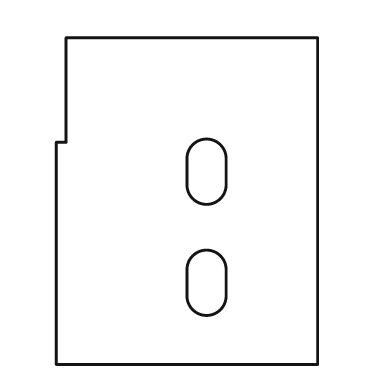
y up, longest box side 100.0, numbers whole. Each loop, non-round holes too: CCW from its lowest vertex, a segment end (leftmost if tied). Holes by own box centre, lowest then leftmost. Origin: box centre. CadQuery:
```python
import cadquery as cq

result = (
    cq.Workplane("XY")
    .moveTo(-40.0, -50.0)
    .lineTo(40.0, -50.0)
    .lineTo(40.0, 50.0)
    .lineTo(-37.0, 50.0)
    .lineTo(-37.0, 18.0)
    .lineTo(-40.0, 18.0)
    .close()
    .moveTo(0.0, -29.0)
    .threePointArc((6.0, -35.0), (12.0, -29.0))
    .lineTo(12.0, -21.0)
    .threePointArc((6.0, -15.0), (0.0, -21.0))
    .close()
    .moveTo(0.0, 5.0)
    .threePointArc((6.0, -1.0), (12.0, 5.0))
    .lineTo(12.0, 13.0)
    .threePointArc((6.0, 19.0), (0.0, 13.0))
    .close()
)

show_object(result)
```